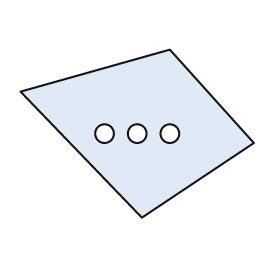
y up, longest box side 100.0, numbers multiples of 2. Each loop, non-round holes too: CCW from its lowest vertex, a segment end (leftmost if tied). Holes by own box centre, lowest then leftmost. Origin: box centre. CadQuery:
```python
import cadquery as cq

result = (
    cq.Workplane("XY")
    .moveTo(2.0, -36.0)
    .lineTo(50.0, -4.0)
    .lineTo(14.0, 36.0)
    .lineTo(-50.0, 18.0)
    .close()
    .moveTo(-14.0, 0.0)
    .circle(4.0)
    .moveTo(0.0, 0.0)
    .circle(4.0)
    .moveTo(14.0, 0.0)
    .circle(4.0)
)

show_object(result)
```